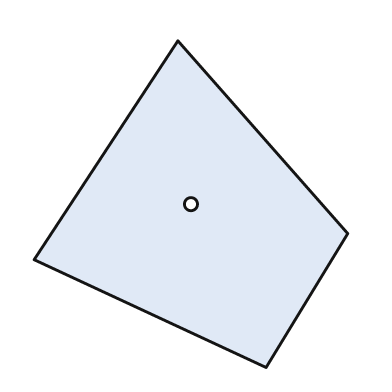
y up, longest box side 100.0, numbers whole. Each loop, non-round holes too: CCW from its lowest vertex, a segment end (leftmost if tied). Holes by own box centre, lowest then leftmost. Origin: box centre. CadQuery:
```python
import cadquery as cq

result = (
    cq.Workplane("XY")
    .moveTo(23.0, -50.0)
    .lineTo(48.0, -9.0)
    .lineTo(-4.0, 50.0)
    .lineTo(-48.0, -17.0)
    .close()
    .moveTo(0.0, 0.0)
    .circle(2.0)
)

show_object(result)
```